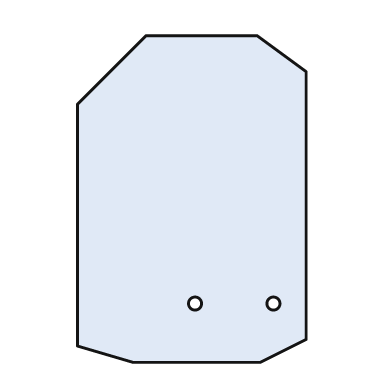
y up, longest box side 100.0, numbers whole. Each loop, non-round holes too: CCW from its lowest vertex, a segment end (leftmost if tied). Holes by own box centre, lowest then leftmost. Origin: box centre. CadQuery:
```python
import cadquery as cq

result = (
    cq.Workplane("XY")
    .moveTo(-18.0, -50.0)
    .lineTo(21.0, -50.0)
    .lineTo(35.0, -43.0)
    .lineTo(35.0, 39.0)
    .lineTo(20.0, 50.0)
    .lineTo(-14.0, 50.0)
    .lineTo(-35.0, 29.0)
    .lineTo(-35.0, -45.0)
    .close()
    .moveTo(1.0, -32.0)
    .circle(2.0)
    .moveTo(25.0, -32.0)
    .circle(2.0)
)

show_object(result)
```